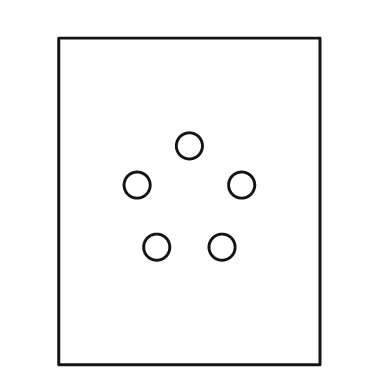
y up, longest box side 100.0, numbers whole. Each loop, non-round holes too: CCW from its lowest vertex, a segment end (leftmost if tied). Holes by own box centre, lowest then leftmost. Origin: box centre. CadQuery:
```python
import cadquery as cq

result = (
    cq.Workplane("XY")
    .moveTo(-40.0, -50.0)
    .lineTo(40.0, -50.0)
    .lineTo(40.0, 50.0)
    .lineTo(-40.0, 50.0)
    .close()
    .moveTo(-10.0, -14.0)
    .circle(4.0)
    .moveTo(10.0, -14.0)
    .circle(4.0)
    .moveTo(-16.0, 5.0)
    .circle(4.0)
    .moveTo(16.0, 5.0)
    .circle(4.0)
    .moveTo(0.0, 17.0)
    .circle(4.0)
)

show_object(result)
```